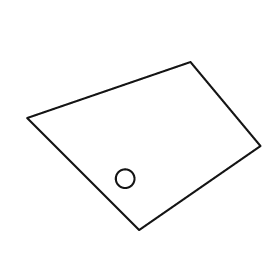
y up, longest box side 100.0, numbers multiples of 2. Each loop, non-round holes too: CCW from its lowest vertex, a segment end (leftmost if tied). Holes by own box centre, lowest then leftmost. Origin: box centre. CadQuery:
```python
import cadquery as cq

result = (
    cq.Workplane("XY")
    .moveTo(-2.0, -36.0)
    .lineTo(50.0, 0.0)
    .lineTo(20.0, 36.0)
    .lineTo(-50.0, 12.0)
    .close()
    .moveTo(-8.0, -14.0)
    .circle(4.0)
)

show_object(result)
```